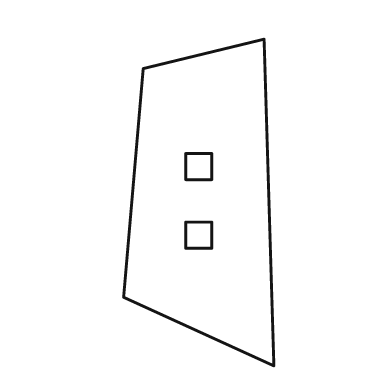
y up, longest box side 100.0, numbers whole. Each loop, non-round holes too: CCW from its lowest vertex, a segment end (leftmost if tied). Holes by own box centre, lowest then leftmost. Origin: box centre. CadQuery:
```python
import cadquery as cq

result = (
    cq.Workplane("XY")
    .moveTo(23.0, -50.0)
    .lineTo(20.0, 50.0)
    .lineTo(-17.0, 41.0)
    .lineTo(-23.0, -29.0)
    .close()
    .moveTo(-4.0, -14.0)
    .lineTo(4.0, -14.0)
    .lineTo(4.0, -6.0)
    .lineTo(-4.0, -6.0)
    .close()
    .moveTo(-4.0, 7.0)
    .lineTo(4.0, 7.0)
    .lineTo(4.0, 15.0)
    .lineTo(-4.0, 15.0)
    .close()
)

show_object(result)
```